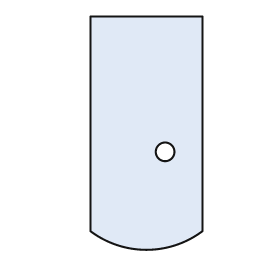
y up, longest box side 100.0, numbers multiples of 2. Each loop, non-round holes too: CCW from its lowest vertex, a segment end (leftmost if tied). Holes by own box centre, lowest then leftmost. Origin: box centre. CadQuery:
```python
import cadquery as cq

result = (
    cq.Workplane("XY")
    .moveTo(-24.0, -42.0)
    .threePointArc((0.0, -50.0), (24.0, -42.0))
    .lineTo(24.0, 50.0)
    .lineTo(-24.0, 50.0)
    .close()
    .moveTo(8.0, -8.0)
    .circle(4.0)
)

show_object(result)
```